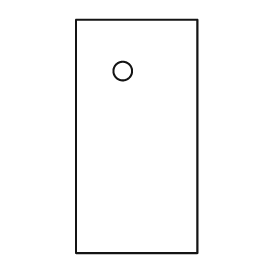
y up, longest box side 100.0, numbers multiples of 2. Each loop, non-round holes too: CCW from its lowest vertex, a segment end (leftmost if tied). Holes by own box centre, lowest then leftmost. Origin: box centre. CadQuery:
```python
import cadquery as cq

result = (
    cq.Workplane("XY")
    .moveTo(-26.0, -50.0)
    .lineTo(26.0, -50.0)
    .lineTo(26.0, 50.0)
    .lineTo(-26.0, 50.0)
    .close()
    .moveTo(-6.0, 28.0)
    .circle(4.0)
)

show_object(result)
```